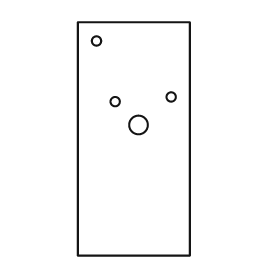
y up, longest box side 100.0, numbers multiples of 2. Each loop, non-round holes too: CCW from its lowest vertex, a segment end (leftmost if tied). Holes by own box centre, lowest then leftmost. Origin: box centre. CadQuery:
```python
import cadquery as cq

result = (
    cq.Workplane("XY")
    .moveTo(-24.0, -50.0)
    .lineTo(24.0, -50.0)
    .lineTo(24.0, 50.0)
    .lineTo(-24.0, 50.0)
    .close()
    .moveTo(2.0, 6.0)
    .circle(4.0)
    .moveTo(-8.0, 16.0)
    .circle(2.0)
    .moveTo(16.0, 18.0)
    .circle(2.0)
    .moveTo(-16.0, 42.0)
    .circle(2.0)
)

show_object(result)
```